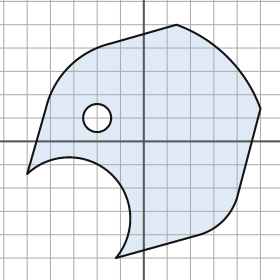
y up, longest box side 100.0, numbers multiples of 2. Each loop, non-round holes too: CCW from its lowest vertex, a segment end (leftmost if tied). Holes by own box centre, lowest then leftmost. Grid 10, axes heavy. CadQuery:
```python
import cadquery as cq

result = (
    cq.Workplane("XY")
    .moveTo(-12.0, -50.0)
    .lineTo(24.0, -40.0)
    .threePointArc((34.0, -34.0), (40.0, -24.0))
    .lineTo(50.0, 14.0)
    .threePointArc((36.0, 36.0), (14.0, 50.0))
    .lineTo(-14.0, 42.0)
    .threePointArc((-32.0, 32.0), (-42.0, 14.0))
    .lineTo(-50.0, -14.0)
    .threePointArc((-14.0, -14.0), (-12.0, -50.0))
    .close()
    .moveTo(-20.0, 10.0)
    .circle(6.0)
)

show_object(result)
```